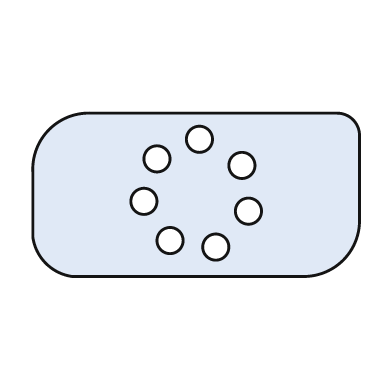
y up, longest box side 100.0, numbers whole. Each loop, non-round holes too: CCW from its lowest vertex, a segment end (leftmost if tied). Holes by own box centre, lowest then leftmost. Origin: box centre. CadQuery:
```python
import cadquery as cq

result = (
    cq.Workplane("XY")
    .moveTo(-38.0, -25.0)
    .lineTo(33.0, -25.0)
    .threePointArc((45.0, -20.0), (50.0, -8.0))
    .lineTo(50.0, 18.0)
    .threePointArc((48.0, 23.0), (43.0, 25.0))
    .lineTo(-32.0, 25.0)
    .threePointArc((-45.0, 20.0), (-50.0, 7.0))
    .lineTo(-50.0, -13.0)
    .threePointArc((-46.0, -21.0), (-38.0, -25.0))
    .close()
    .moveTo(6.0, -16.0)
    .circle(4.0)
    .moveTo(-8.0, -14.0)
    .circle(4.0)
    .moveTo(16.0, -5.0)
    .circle(4.0)
    .moveTo(-16.0, -2.0)
    .circle(4.0)
    .moveTo(14.0, 9.0)
    .circle(4.0)
    .moveTo(-12.0, 11.0)
    .circle(4.0)
    .moveTo(1.0, 17.0)
    .circle(4.0)
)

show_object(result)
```